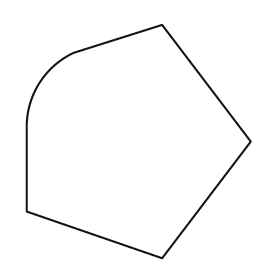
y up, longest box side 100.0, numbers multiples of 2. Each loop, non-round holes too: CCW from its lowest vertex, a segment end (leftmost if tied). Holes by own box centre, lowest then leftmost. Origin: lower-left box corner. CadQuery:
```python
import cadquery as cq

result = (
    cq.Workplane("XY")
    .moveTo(58.0, 0.0)
    .lineTo(96.0, 50.0)
    .lineTo(58.0, 100.0)
    .lineTo(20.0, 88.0)
    .threePointArc((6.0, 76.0), (0.0, 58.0))
    .lineTo(0.0, 20.0)
    .close()
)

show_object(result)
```